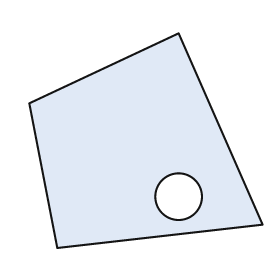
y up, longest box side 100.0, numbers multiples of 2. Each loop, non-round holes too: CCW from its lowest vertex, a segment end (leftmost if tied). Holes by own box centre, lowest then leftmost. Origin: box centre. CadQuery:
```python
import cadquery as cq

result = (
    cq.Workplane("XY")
    .moveTo(-38.0, -46.0)
    .lineTo(50.0, -36.0)
    .lineTo(14.0, 46.0)
    .lineTo(-50.0, 16.0)
    .close()
    .moveTo(14.0, -24.0)
    .circle(10.0)
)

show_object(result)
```